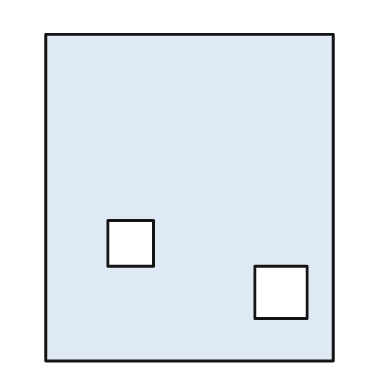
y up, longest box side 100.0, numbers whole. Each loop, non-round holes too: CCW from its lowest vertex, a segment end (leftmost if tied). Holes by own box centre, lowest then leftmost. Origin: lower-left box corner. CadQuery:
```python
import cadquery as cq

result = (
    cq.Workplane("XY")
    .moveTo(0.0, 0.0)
    .lineTo(88.0, 0.0)
    .lineTo(88.0, 100.0)
    .lineTo(0.0, 100.0)
    .close()
    .moveTo(64.0, 13.0)
    .lineTo(80.0, 13.0)
    .lineTo(80.0, 29.0)
    .lineTo(64.0, 29.0)
    .close()
    .moveTo(19.0, 29.0)
    .lineTo(33.0, 29.0)
    .lineTo(33.0, 43.0)
    .lineTo(19.0, 43.0)
    .close()
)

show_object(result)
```